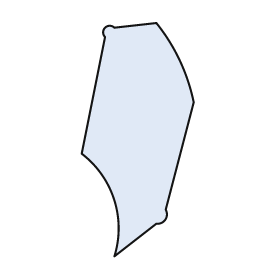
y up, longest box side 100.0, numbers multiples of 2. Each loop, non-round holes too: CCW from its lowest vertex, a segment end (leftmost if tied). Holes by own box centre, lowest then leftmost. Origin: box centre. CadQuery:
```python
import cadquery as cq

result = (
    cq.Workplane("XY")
    .moveTo(-10.0, -50.0)
    .lineTo(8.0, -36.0)
    .threePointArc((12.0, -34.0), (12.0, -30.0))
    .lineTo(24.0, 16.0)
    .threePointArc((18.0, 34.0), (8.0, 50.0))
    .lineTo(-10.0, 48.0)
    .threePointArc((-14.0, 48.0), (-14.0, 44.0))
    .lineTo(-24.0, -6.0)
    .threePointArc((-10.0, -26.0), (-10.0, -50.0))
    .close()
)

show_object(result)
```